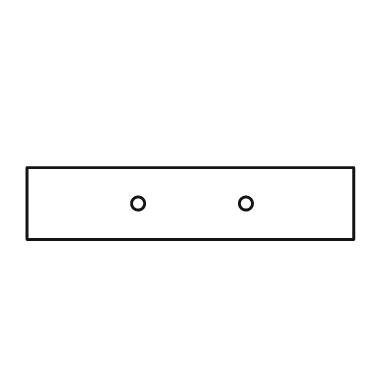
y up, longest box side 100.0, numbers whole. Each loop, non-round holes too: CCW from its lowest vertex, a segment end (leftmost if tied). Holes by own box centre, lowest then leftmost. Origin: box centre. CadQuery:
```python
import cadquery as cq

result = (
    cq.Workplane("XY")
    .moveTo(-50.0, -11.0)
    .lineTo(50.0, -11.0)
    .lineTo(50.0, 11.0)
    .lineTo(-50.0, 11.0)
    .close()
    .moveTo(-16.0, 0.0)
    .circle(2.0)
    .moveTo(17.0, 0.0)
    .circle(2.0)
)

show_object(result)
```